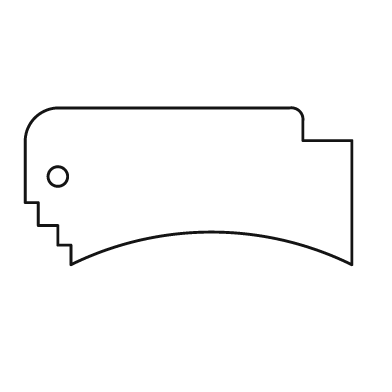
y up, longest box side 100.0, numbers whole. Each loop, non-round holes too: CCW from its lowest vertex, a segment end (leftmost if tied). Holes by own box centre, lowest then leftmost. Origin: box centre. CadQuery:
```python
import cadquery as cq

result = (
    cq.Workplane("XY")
    .moveTo(-36.0, -24.0)
    .threePointArc((7.0, -14.0), (50.0, -24.0))
    .lineTo(50.0, 14.0)
    .lineTo(35.0, 14.0)
    .lineTo(35.0, 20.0)
    .threePointArc((34.0, 23.0), (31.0, 24.0))
    .lineTo(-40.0, 24.0)
    .threePointArc((-47.0, 21.0), (-50.0, 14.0))
    .lineTo(-50.0, -5.0)
    .lineTo(-46.0, -5.0)
    .lineTo(-46.0, -12.0)
    .lineTo(-40.0, -12.0)
    .lineTo(-40.0, -18.0)
    .lineTo(-36.0, -18.0)
    .close()
    .moveTo(-40.0, 3.0)
    .circle(3.0)
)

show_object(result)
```